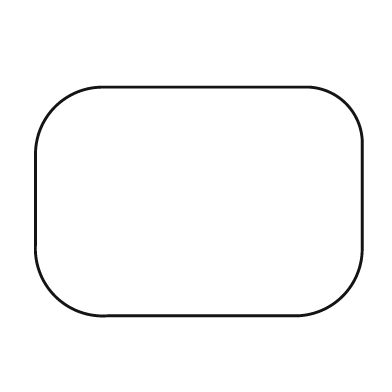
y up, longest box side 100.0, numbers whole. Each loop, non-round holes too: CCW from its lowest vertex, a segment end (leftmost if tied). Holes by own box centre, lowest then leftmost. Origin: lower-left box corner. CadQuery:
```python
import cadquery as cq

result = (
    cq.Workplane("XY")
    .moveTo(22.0, 0.0)
    .lineTo(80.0, 0.0)
    .threePointArc((94.0, 6.0), (100.0, 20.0))
    .lineTo(100.0, 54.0)
    .threePointArc((95.0, 65.0), (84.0, 70.0))
    .lineTo(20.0, 70.0)
    .threePointArc((6.0, 64.0), (0.0, 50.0))
    .lineTo(0.0, 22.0)
    .threePointArc((6.0, 6.0), (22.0, 0.0))
    .close()
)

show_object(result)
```